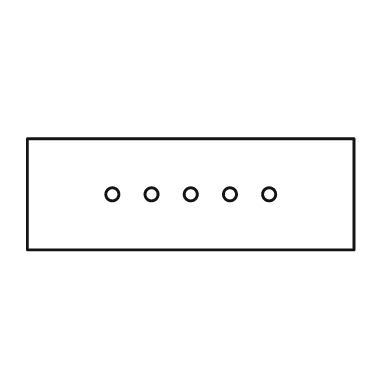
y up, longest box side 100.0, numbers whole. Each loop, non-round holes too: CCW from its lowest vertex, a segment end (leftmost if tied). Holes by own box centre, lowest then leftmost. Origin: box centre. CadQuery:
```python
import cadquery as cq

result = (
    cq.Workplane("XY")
    .moveTo(-50.0, -17.0)
    .lineTo(50.0, -17.0)
    .lineTo(50.0, 17.0)
    .lineTo(-50.0, 17.0)
    .close()
    .moveTo(-24.0, 0.0)
    .circle(2.0)
    .moveTo(-12.0, 0.0)
    .circle(2.0)
    .moveTo(0.0, 0.0)
    .circle(2.0)
    .moveTo(12.0, 0.0)
    .circle(2.0)
    .moveTo(24.0, 0.0)
    .circle(2.0)
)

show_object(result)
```